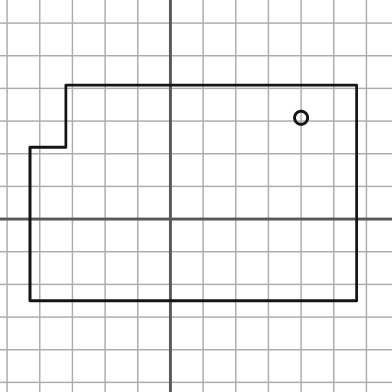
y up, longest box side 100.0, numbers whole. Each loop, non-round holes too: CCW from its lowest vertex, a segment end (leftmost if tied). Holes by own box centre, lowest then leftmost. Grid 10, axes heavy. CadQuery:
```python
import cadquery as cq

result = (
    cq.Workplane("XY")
    .moveTo(-43.0, -25.0)
    .lineTo(57.0, -25.0)
    .lineTo(57.0, 41.0)
    .lineTo(-32.0, 41.0)
    .lineTo(-32.0, 22.0)
    .lineTo(-43.0, 22.0)
    .close()
    .moveTo(40.0, 31.0)
    .circle(2.0)
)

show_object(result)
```